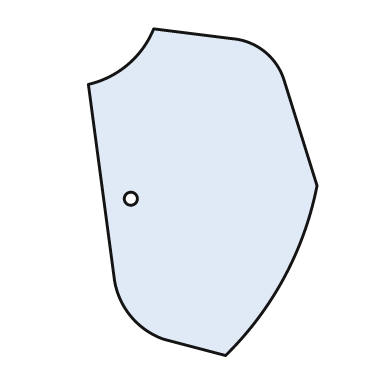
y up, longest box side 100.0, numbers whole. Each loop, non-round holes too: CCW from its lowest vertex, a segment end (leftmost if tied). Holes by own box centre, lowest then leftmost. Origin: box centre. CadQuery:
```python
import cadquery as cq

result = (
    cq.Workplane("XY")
    .moveTo(7.0, -50.0)
    .threePointArc((25.0, -26.0), (35.0, 2.0))
    .lineTo(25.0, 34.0)
    .threePointArc((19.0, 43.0), (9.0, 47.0))
    .lineTo(-15.0, 50.0)
    .threePointArc((-23.0, 39.0), (-35.0, 33.0))
    .lineTo(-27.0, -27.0)
    .threePointArc((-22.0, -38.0), (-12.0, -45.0))
    .close()
    .moveTo(-22.0, -2.0)
    .circle(2.0)
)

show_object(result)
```